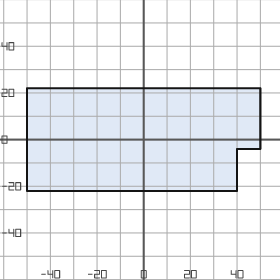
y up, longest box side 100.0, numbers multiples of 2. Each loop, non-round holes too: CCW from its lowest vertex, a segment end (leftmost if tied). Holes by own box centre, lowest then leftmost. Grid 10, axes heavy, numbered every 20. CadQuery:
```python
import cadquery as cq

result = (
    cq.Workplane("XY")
    .moveTo(-50.0, -22.0)
    .lineTo(40.0, -22.0)
    .lineTo(40.0, -4.0)
    .lineTo(50.0, -4.0)
    .lineTo(50.0, 22.0)
    .lineTo(-50.0, 22.0)
    .close()
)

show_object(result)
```